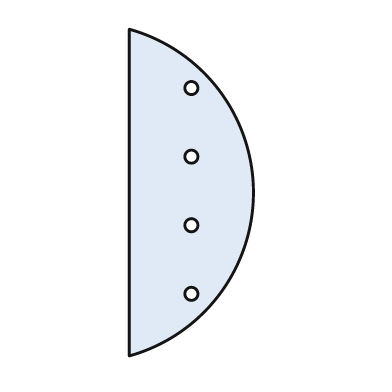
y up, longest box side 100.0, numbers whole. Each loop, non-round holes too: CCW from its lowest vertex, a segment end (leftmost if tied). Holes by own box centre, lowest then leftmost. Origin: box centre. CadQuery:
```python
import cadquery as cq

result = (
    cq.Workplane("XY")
    .moveTo(-19.0, -50.0)
    .threePointArc((19.0, 0.0), (-19.0, 50.0))
    .close()
    .moveTo(0.0, -31.0)
    .circle(2.0)
    .moveTo(0.0, -10.0)
    .circle(2.0)
    .moveTo(0.0, 11.0)
    .circle(2.0)
    .moveTo(0.0, 32.0)
    .circle(2.0)
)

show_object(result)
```